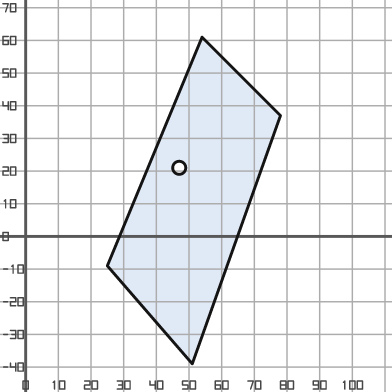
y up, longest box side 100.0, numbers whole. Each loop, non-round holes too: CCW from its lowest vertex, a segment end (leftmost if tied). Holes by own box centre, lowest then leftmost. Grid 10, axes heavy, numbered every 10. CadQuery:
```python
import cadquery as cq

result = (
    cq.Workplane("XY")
    .moveTo(51.0, -39.0)
    .lineTo(78.0, 37.0)
    .lineTo(54.0, 61.0)
    .lineTo(25.0, -9.0)
    .close()
    .moveTo(47.0, 21.0)
    .circle(2.0)
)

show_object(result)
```